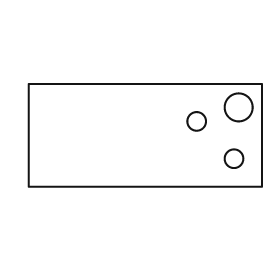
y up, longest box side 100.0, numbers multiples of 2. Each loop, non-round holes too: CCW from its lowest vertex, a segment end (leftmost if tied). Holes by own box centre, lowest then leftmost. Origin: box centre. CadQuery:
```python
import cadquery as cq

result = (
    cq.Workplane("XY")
    .moveTo(-50.0, -22.0)
    .lineTo(50.0, -22.0)
    .lineTo(50.0, 22.0)
    .lineTo(-50.0, 22.0)
    .close()
    .moveTo(38.0, -10.0)
    .circle(4.0)
    .moveTo(22.0, 6.0)
    .circle(4.0)
    .moveTo(40.0, 12.0)
    .circle(6.0)
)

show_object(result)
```